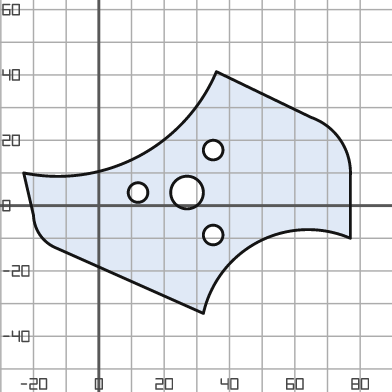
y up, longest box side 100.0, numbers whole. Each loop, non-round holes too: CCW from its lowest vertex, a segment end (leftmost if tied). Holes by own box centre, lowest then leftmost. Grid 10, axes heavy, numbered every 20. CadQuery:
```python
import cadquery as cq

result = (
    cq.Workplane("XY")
    .moveTo(32.0, -33.0)
    .threePointArc((49.0, -11.0), (77.0, -10.0))
    .lineTo(77.0, 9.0)
    .threePointArc((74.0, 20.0), (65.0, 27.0))
    .lineTo(36.0, 41.0)
    .threePointArc((12.0, 15.0), (-23.0, 10.0))
    .lineTo(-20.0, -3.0)
    .threePointArc((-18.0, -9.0), (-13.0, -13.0))
    .close()
    .moveTo(35.0, -9.0)
    .circle(3.0)
    .moveTo(12.0, 4.0)
    .circle(3.0)
    .moveTo(27.0, 4.0)
    .circle(5.0)
    .moveTo(35.0, 17.0)
    .circle(3.0)
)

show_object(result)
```